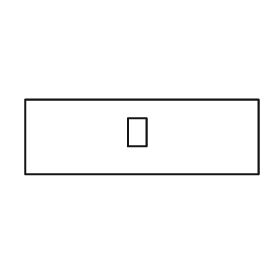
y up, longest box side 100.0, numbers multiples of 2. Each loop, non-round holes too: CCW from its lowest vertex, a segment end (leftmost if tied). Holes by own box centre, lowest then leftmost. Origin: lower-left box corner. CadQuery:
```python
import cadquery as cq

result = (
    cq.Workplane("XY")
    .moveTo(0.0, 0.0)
    .lineTo(100.0, 0.0)
    .lineTo(100.0, 32.0)
    .lineTo(0.0, 32.0)
    .close()
    .moveTo(44.0, 12.0)
    .lineTo(52.0, 12.0)
    .lineTo(52.0, 24.0)
    .lineTo(44.0, 24.0)
    .close()
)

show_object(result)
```